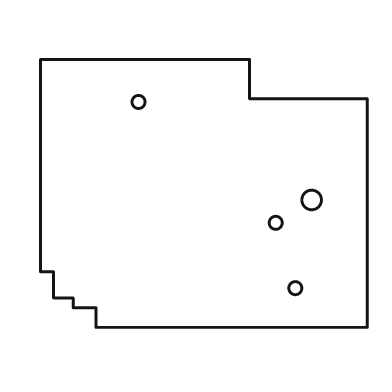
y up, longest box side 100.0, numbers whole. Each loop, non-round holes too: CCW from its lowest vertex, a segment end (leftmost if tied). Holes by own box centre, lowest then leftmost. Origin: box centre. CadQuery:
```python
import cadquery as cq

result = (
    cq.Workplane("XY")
    .moveTo(-33.0, -41.0)
    .lineTo(50.0, -41.0)
    .lineTo(50.0, 29.0)
    .lineTo(14.0, 29.0)
    .lineTo(14.0, 41.0)
    .lineTo(-50.0, 41.0)
    .lineTo(-50.0, -24.0)
    .lineTo(-46.0, -24.0)
    .lineTo(-46.0, -32.0)
    .lineTo(-40.0, -32.0)
    .lineTo(-40.0, -35.0)
    .lineTo(-33.0, -35.0)
    .close()
    .moveTo(28.0, -29.0)
    .circle(2.0)
    .moveTo(22.0, -9.0)
    .circle(2.0)
    .moveTo(33.0, -2.0)
    .circle(3.0)
    .moveTo(-20.0, 28.0)
    .circle(2.0)
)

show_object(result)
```